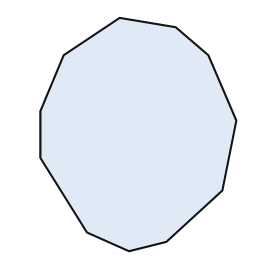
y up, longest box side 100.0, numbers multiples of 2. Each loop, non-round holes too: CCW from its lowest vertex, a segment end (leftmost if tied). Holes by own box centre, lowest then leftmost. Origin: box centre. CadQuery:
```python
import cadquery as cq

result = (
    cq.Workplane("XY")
    .moveTo(-4.0, -50.0)
    .lineTo(12.0, -46.0)
    .lineTo(36.0, -24.0)
    .lineTo(42.0, 6.0)
    .lineTo(30.0, 34.0)
    .lineTo(16.0, 46.0)
    .lineTo(-8.0, 50.0)
    .lineTo(-32.0, 34.0)
    .lineTo(-42.0, 10.0)
    .lineTo(-42.0, -10.0)
    .lineTo(-22.0, -42.0)
    .close()
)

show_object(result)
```